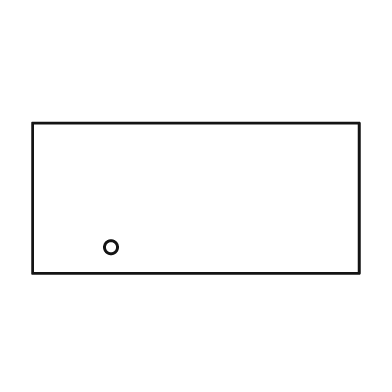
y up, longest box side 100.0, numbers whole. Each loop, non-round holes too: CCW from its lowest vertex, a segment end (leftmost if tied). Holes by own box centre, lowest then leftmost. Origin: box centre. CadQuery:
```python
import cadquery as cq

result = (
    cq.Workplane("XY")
    .moveTo(-50.0, -23.0)
    .lineTo(50.0, -23.0)
    .lineTo(50.0, 23.0)
    .lineTo(-50.0, 23.0)
    .close()
    .moveTo(-26.0, -15.0)
    .circle(2.0)
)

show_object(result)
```